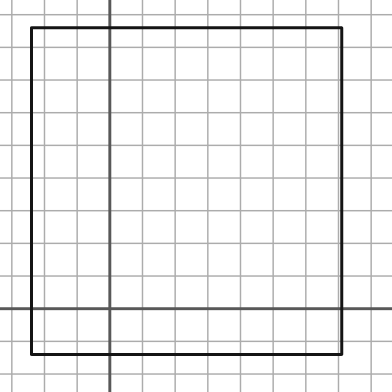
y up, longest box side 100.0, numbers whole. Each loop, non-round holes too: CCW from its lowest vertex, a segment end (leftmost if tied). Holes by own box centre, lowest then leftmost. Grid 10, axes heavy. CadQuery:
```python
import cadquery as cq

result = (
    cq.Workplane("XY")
    .moveTo(-24.0, -14.0)
    .lineTo(71.0, -14.0)
    .lineTo(71.0, 86.0)
    .lineTo(-24.0, 86.0)
    .close()
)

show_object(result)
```